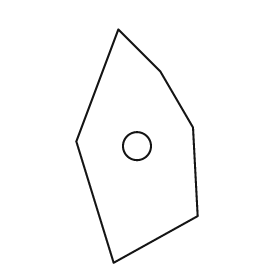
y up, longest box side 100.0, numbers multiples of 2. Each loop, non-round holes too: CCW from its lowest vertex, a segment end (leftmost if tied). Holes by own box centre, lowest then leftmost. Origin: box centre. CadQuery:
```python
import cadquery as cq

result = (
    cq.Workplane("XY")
    .moveTo(-10.0, -50.0)
    .lineTo(26.0, -30.0)
    .lineTo(24.0, 8.0)
    .lineTo(10.0, 32.0)
    .lineTo(-8.0, 50.0)
    .lineTo(-26.0, 2.0)
    .close()
    .moveTo(0.0, 0.0)
    .circle(6.0)
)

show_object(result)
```